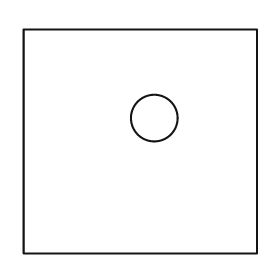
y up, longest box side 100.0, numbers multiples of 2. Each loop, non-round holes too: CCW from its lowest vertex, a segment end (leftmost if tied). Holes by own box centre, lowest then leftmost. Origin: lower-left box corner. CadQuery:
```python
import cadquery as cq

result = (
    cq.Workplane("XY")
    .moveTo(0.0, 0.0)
    .lineTo(100.0, 0.0)
    .lineTo(100.0, 96.0)
    .lineTo(0.0, 96.0)
    .close()
    .moveTo(56.0, 58.0)
    .circle(10.0)
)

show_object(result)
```